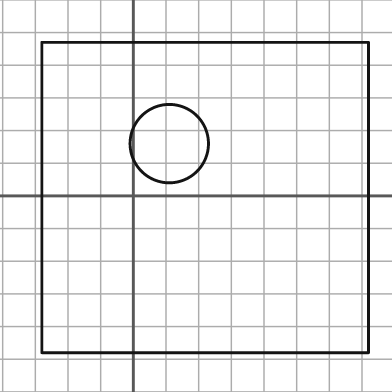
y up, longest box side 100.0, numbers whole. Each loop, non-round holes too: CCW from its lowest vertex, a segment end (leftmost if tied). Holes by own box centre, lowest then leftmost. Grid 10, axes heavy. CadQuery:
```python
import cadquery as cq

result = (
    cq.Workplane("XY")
    .moveTo(-28.0, -48.0)
    .lineTo(72.0, -48.0)
    .lineTo(72.0, 47.0)
    .lineTo(-28.0, 47.0)
    .close()
    .moveTo(11.0, 16.0)
    .circle(12.0)
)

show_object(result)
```